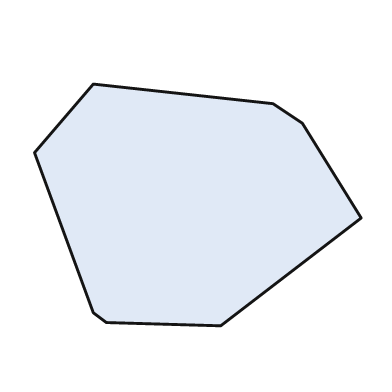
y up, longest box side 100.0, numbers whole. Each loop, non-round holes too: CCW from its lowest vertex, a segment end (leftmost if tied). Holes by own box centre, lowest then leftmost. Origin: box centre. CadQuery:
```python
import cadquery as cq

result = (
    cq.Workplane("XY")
    .moveTo(7.0, -37.0)
    .lineTo(50.0, -4.0)
    .lineTo(32.0, 25.0)
    .lineTo(23.0, 31.0)
    .lineTo(-32.0, 37.0)
    .lineTo(-50.0, 16.0)
    .lineTo(-32.0, -33.0)
    .lineTo(-28.0, -36.0)
    .close()
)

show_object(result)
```